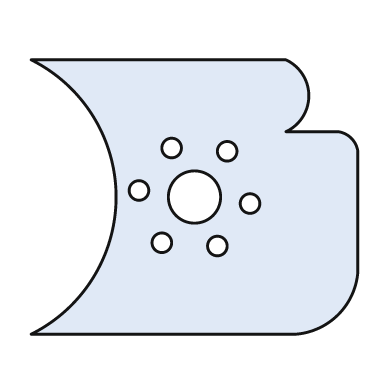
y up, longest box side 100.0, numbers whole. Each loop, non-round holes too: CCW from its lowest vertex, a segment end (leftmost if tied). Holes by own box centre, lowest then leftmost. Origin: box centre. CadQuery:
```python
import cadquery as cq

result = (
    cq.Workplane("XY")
    .moveTo(-50.0, -42.0)
    .lineTo(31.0, -42.0)
    .threePointArc((44.0, -36.0), (50.0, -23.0))
    .lineTo(50.0, 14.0)
    .threePointArc((48.0, 18.0), (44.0, 20.0))
    .lineTo(28.0, 20.0)
    .threePointArc((35.0, 31.0), (28.0, 42.0))
    .lineTo(-50.0, 42.0)
    .threePointArc((-24.0, 0.0), (-50.0, -42.0))
    .close()
    .moveTo(7.0, -15.0)
    .circle(3.0)
    .moveTo(-10.0, -14.0)
    .circle(3.0)
    .moveTo(17.0, -2.0)
    .circle(3.0)
    .moveTo(0.0, 0.0)
    .circle(8.0)
    .moveTo(-17.0, 2.0)
    .circle(3.0)
    .moveTo(10.0, 14.0)
    .circle(3.0)
    .moveTo(-7.0, 15.0)
    .circle(3.0)
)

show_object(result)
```